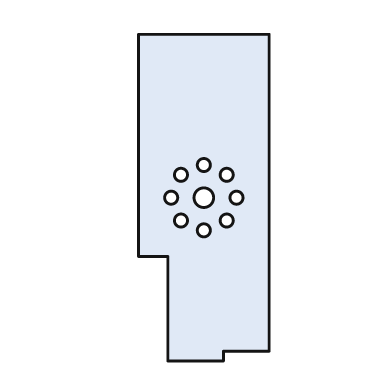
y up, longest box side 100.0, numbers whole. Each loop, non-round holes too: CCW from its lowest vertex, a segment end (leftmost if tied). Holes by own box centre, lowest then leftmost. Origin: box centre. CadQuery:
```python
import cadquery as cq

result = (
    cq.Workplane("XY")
    .moveTo(-11.0, -50.0)
    .lineTo(6.0, -50.0)
    .lineTo(6.0, -47.0)
    .lineTo(20.0, -47.0)
    .lineTo(20.0, 50.0)
    .lineTo(-20.0, 50.0)
    .lineTo(-20.0, -18.0)
    .lineTo(-11.0, -18.0)
    .close()
    .moveTo(0.0, -10.0)
    .circle(2.0)
    .moveTo(-7.0, -7.0)
    .circle(2.0)
    .moveTo(7.0, -7.0)
    .circle(2.0)
    .moveTo(-10.0, 0.0)
    .circle(2.0)
    .moveTo(0.0, 0.0)
    .circle(3.0)
    .moveTo(10.0, 0.0)
    .circle(2.0)
    .moveTo(-7.0, 7.0)
    .circle(2.0)
    .moveTo(7.0, 7.0)
    .circle(2.0)
    .moveTo(0.0, 10.0)
    .circle(2.0)
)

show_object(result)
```